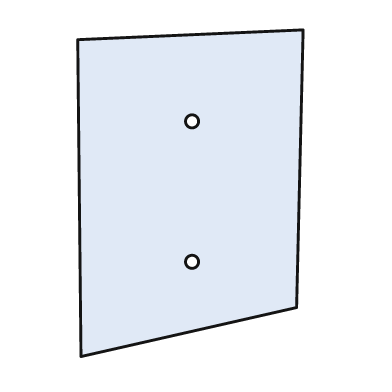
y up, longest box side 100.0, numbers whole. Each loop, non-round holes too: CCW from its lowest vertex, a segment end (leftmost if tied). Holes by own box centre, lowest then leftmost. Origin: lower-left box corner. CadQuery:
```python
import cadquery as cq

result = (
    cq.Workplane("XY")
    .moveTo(1.0, 0.0)
    .lineTo(67.0, 15.0)
    .lineTo(69.0, 100.0)
    .lineTo(0.0, 97.0)
    .close()
    .moveTo(35.0, 29.0)
    .circle(2.0)
    .moveTo(35.0, 72.0)
    .circle(2.0)
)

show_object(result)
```